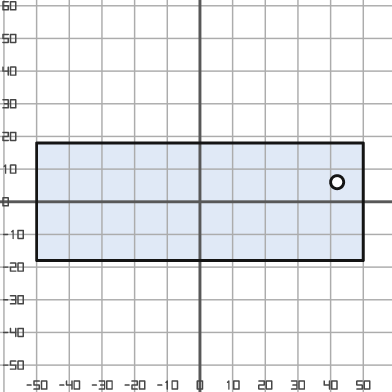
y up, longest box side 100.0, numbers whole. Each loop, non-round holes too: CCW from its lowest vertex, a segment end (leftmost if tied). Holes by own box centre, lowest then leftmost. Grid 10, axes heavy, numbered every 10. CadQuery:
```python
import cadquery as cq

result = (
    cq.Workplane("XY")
    .moveTo(-50.0, -18.0)
    .lineTo(50.0, -18.0)
    .lineTo(50.0, 18.0)
    .lineTo(-50.0, 18.0)
    .close()
    .moveTo(42.0, 6.0)
    .circle(2.0)
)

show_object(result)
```